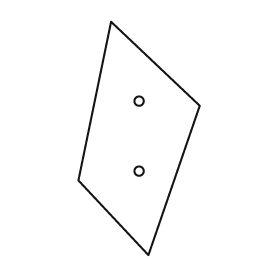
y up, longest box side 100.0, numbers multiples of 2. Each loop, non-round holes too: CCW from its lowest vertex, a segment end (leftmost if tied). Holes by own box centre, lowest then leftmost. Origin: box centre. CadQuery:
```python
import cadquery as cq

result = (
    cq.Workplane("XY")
    .moveTo(4.0, -50.0)
    .lineTo(26.0, 14.0)
    .lineTo(-12.0, 50.0)
    .lineTo(-26.0, -18.0)
    .close()
    .moveTo(0.0, -14.0)
    .circle(2.0)
    .moveTo(0.0, 16.0)
    .circle(2.0)
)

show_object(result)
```